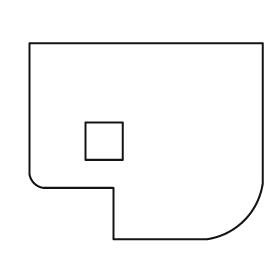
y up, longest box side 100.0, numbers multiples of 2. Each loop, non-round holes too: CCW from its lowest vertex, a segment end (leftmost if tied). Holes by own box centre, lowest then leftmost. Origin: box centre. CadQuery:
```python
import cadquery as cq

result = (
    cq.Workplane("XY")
    .moveTo(-14.0, -42.0)
    .lineTo(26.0, -42.0)
    .threePointArc((42.0, -34.0), (50.0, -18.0))
    .lineTo(50.0, 42.0)
    .lineTo(-50.0, 42.0)
    .lineTo(-50.0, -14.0)
    .threePointArc((-48.0, -18.0), (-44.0, -20.0))
    .lineTo(-14.0, -20.0)
    .close()
    .moveTo(-26.0, -8.0)
    .lineTo(-10.0, -8.0)
    .lineTo(-10.0, 8.0)
    .lineTo(-26.0, 8.0)
    .close()
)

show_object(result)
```